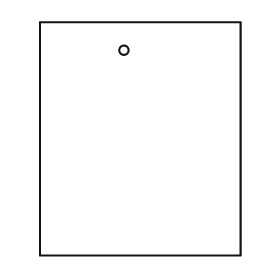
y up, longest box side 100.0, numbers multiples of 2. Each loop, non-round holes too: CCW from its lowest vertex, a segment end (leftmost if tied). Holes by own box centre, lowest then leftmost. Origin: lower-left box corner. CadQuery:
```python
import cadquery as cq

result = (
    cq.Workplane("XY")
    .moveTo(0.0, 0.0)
    .lineTo(86.0, 0.0)
    .lineTo(86.0, 100.0)
    .lineTo(0.0, 100.0)
    .close()
    .moveTo(36.0, 88.0)
    .circle(2.0)
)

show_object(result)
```